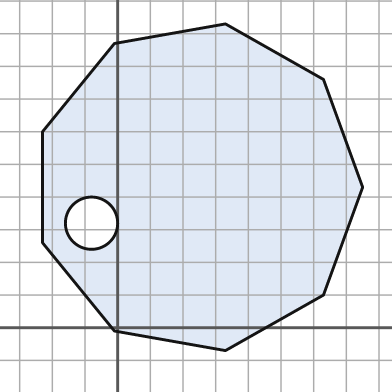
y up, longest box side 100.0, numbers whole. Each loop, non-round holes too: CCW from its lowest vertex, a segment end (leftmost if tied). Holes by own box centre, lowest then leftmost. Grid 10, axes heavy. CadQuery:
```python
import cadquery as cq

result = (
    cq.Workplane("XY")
    .moveTo(33.0, -7.0)
    .lineTo(63.0, 10.0)
    .lineTo(75.0, 43.0)
    .lineTo(63.0, 76.0)
    .lineTo(33.0, 93.0)
    .lineTo(-1.0, 87.0)
    .lineTo(-23.0, 60.0)
    .lineTo(-23.0, 26.0)
    .lineTo(-1.0, -1.0)
    .close()
    .moveTo(-8.0, 32.0)
    .circle(8.0)
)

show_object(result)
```